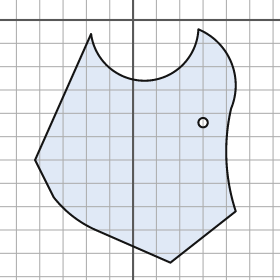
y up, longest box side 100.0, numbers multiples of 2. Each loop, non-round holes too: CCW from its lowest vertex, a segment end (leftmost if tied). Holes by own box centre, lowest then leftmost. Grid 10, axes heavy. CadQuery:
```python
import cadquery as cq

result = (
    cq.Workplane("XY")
    .moveTo(16.0, -104.0)
    .lineTo(44.0, -82.0)
    .threePointArc((40.0, -60.0), (42.0, -38.0))
    .threePointArc((42.0, -18.0), (28.0, -4.0))
    .threePointArc((6.0, -26.0), (-18.0, -6.0))
    .lineTo(-42.0, -60.0)
    .lineTo(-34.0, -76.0)
    .threePointArc((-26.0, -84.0), (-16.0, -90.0))
    .close()
    .moveTo(30.0, -44.0)
    .circle(2.0)
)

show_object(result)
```